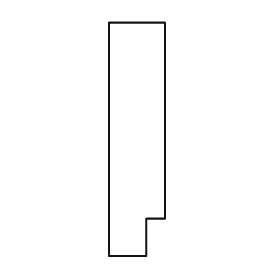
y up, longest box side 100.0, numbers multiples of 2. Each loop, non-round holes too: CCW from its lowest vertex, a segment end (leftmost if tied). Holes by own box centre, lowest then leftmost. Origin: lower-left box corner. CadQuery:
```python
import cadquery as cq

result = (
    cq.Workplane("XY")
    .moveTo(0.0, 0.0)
    .lineTo(16.0, 0.0)
    .lineTo(16.0, 16.0)
    .lineTo(24.0, 16.0)
    .lineTo(24.0, 100.0)
    .lineTo(0.0, 100.0)
    .close()
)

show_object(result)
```